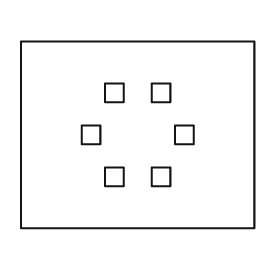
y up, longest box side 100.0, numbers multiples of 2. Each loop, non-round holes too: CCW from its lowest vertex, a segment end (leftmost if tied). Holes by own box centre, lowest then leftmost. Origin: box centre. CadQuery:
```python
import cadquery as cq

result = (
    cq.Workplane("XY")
    .moveTo(-50.0, -40.0)
    .lineTo(50.0, -40.0)
    .lineTo(50.0, 40.0)
    .lineTo(-50.0, 40.0)
    .close()
    .moveTo(-14.0, -22.0)
    .lineTo(-6.0, -22.0)
    .lineTo(-6.0, -14.0)
    .lineTo(-14.0, -14.0)
    .close()
    .moveTo(6.0, -22.0)
    .lineTo(14.0, -22.0)
    .lineTo(14.0, -14.0)
    .lineTo(6.0, -14.0)
    .close()
    .moveTo(-24.0, -4.0)
    .lineTo(-16.0, -4.0)
    .lineTo(-16.0, 4.0)
    .lineTo(-24.0, 4.0)
    .close()
    .moveTo(16.0, -4.0)
    .lineTo(24.0, -4.0)
    .lineTo(24.0, 4.0)
    .lineTo(16.0, 4.0)
    .close()
    .moveTo(-14.0, 14.0)
    .lineTo(-6.0, 14.0)
    .lineTo(-6.0, 22.0)
    .lineTo(-14.0, 22.0)
    .close()
    .moveTo(6.0, 14.0)
    .lineTo(14.0, 14.0)
    .lineTo(14.0, 22.0)
    .lineTo(6.0, 22.0)
    .close()
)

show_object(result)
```